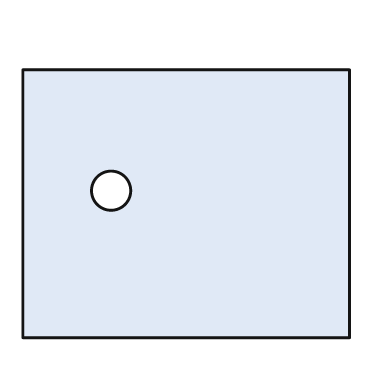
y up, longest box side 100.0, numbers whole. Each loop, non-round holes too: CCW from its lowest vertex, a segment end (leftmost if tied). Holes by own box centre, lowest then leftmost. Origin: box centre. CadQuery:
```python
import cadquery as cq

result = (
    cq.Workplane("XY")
    .moveTo(-50.0, -41.0)
    .lineTo(50.0, -41.0)
    .lineTo(50.0, 41.0)
    .lineTo(-50.0, 41.0)
    .close()
    .moveTo(-23.0, 4.0)
    .circle(6.0)
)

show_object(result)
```